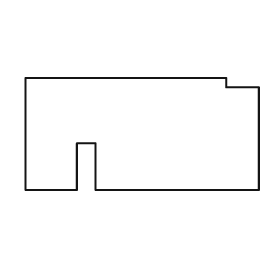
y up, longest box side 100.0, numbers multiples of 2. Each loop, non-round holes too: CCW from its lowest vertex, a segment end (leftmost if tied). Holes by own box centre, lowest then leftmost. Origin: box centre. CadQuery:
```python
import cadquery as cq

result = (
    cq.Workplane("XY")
    .moveTo(-50.0, -24.0)
    .lineTo(-28.0, -24.0)
    .lineTo(-28.0, -4.0)
    .lineTo(-20.0, -4.0)
    .lineTo(-20.0, -24.0)
    .lineTo(50.0, -24.0)
    .lineTo(50.0, 20.0)
    .lineTo(36.0, 20.0)
    .lineTo(36.0, 24.0)
    .lineTo(-50.0, 24.0)
    .close()
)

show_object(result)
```